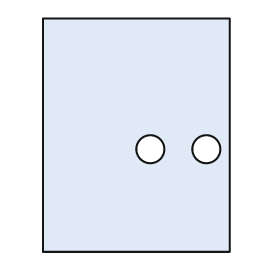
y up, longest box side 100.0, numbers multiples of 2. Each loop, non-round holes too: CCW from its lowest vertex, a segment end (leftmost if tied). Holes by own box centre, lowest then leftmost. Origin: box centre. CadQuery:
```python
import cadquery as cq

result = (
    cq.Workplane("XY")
    .moveTo(-40.0, -50.0)
    .lineTo(40.0, -50.0)
    .lineTo(40.0, 50.0)
    .lineTo(-40.0, 50.0)
    .close()
    .moveTo(6.0, -6.0)
    .circle(6.0)
    .moveTo(30.0, -6.0)
    .circle(6.0)
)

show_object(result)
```